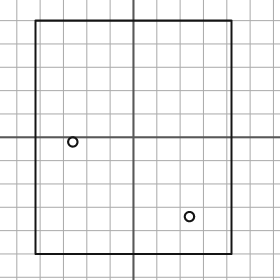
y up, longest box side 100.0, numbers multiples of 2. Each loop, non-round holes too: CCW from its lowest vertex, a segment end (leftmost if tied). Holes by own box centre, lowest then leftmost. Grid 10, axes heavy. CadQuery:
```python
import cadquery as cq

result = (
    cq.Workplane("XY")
    .moveTo(-42.0, -50.0)
    .lineTo(42.0, -50.0)
    .lineTo(42.0, 50.0)
    .lineTo(-42.0, 50.0)
    .close()
    .moveTo(24.0, -34.0)
    .circle(2.0)
    .moveTo(-26.0, -2.0)
    .circle(2.0)
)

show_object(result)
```